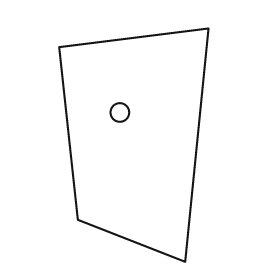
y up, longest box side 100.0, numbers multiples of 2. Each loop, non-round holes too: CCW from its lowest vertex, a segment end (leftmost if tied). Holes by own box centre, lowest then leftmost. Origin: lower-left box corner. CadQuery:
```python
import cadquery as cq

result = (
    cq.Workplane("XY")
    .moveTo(54.0, 0.0)
    .lineTo(64.0, 100.0)
    .lineTo(0.0, 92.0)
    .lineTo(8.0, 18.0)
    .close()
    .moveTo(26.0, 64.0)
    .circle(4.0)
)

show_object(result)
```